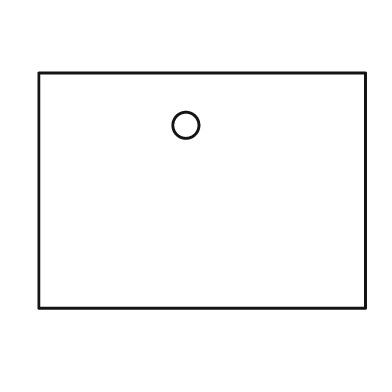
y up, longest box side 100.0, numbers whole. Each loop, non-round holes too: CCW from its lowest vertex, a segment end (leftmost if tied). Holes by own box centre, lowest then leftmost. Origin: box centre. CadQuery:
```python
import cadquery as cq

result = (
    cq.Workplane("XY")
    .moveTo(-50.0, -36.0)
    .lineTo(50.0, -36.0)
    .lineTo(50.0, 36.0)
    .lineTo(-50.0, 36.0)
    .close()
    .moveTo(-5.0, 20.0)
    .circle(4.0)
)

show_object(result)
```